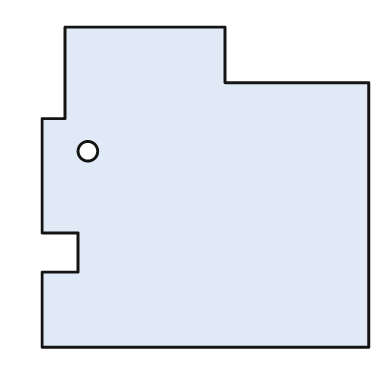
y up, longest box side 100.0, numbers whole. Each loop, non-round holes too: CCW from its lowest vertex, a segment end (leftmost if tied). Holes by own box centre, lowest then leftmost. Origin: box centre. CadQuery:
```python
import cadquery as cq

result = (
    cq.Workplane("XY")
    .moveTo(-50.0, -49.0)
    .lineTo(50.0, -49.0)
    .lineTo(50.0, 32.0)
    .lineTo(6.0, 32.0)
    .lineTo(6.0, 49.0)
    .lineTo(-43.0, 49.0)
    .lineTo(-43.0, 21.0)
    .lineTo(-50.0, 21.0)
    .lineTo(-50.0, -14.0)
    .lineTo(-39.0, -14.0)
    .lineTo(-39.0, -26.0)
    .lineTo(-50.0, -26.0)
    .close()
    .moveTo(-36.0, 11.0)
    .circle(3.0)
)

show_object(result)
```